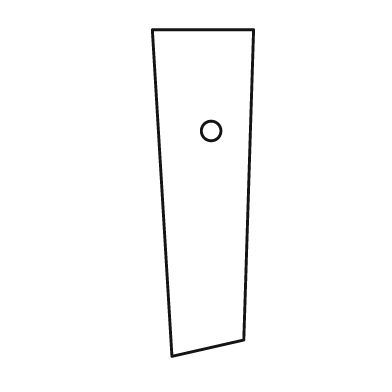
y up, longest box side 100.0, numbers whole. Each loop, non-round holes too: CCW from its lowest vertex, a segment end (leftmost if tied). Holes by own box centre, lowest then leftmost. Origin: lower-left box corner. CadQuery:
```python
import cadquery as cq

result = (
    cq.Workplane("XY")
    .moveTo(6.0, 0.0)
    .lineTo(28.0, 5.0)
    .lineTo(31.0, 100.0)
    .lineTo(0.0, 100.0)
    .close()
    .moveTo(18.0, 69.0)
    .circle(3.0)
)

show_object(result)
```